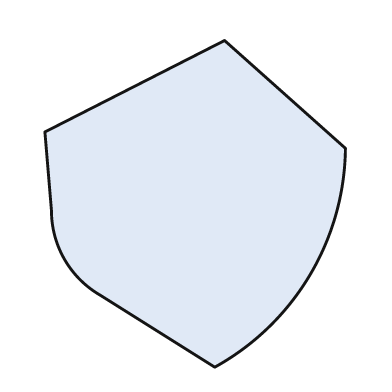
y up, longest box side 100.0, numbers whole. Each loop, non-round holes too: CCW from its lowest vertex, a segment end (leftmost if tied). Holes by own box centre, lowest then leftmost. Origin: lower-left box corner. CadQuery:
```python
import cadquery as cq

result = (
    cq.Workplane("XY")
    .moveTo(52.0, 0.0)
    .threePointArc((81.0, 28.0), (92.0, 67.0))
    .lineTo(55.0, 100.0)
    .lineTo(0.0, 72.0)
    .lineTo(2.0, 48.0)
    .threePointArc((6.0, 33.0), (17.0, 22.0))
    .close()
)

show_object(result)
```